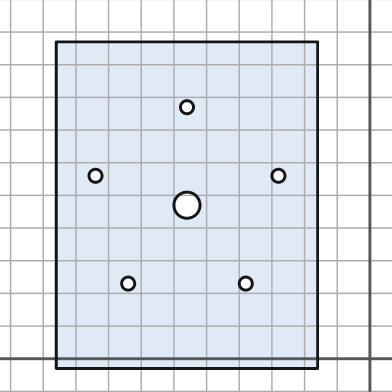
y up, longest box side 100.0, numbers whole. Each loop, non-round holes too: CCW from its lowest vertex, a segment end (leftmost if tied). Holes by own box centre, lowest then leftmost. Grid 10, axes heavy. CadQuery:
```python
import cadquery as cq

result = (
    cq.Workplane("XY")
    .moveTo(-96.0, -3.0)
    .lineTo(-16.0, -3.0)
    .lineTo(-16.0, 97.0)
    .lineTo(-96.0, 97.0)
    .close()
    .moveTo(-74.0, 23.0)
    .circle(2.0)
    .moveTo(-38.0, 23.0)
    .circle(2.0)
    .moveTo(-56.0, 47.0)
    .circle(4.0)
    .moveTo(-84.0, 56.0)
    .circle(2.0)
    .moveTo(-28.0, 56.0)
    .circle(2.0)
    .moveTo(-56.0, 77.0)
    .circle(2.0)
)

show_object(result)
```